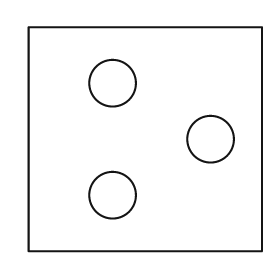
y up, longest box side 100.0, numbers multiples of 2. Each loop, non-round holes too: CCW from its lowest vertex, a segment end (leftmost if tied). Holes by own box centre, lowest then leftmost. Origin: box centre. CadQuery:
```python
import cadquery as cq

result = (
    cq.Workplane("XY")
    .moveTo(-50.0, -48.0)
    .lineTo(50.0, -48.0)
    .lineTo(50.0, 48.0)
    .lineTo(-50.0, 48.0)
    .close()
    .moveTo(-14.0, -24.0)
    .circle(10.0)
    .moveTo(28.0, 0.0)
    .circle(10.0)
    .moveTo(-14.0, 24.0)
    .circle(10.0)
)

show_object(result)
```